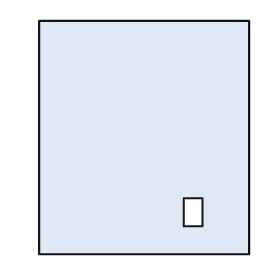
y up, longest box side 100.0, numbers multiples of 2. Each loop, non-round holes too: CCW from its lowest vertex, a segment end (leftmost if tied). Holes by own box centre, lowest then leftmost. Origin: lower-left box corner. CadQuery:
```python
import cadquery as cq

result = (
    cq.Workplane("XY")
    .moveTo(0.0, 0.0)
    .lineTo(90.0, 0.0)
    .lineTo(90.0, 100.0)
    .lineTo(0.0, 100.0)
    .close()
    .moveTo(62.0, 12.0)
    .lineTo(70.0, 12.0)
    .lineTo(70.0, 24.0)
    .lineTo(62.0, 24.0)
    .close()
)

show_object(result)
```